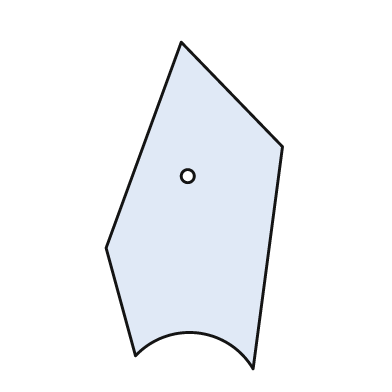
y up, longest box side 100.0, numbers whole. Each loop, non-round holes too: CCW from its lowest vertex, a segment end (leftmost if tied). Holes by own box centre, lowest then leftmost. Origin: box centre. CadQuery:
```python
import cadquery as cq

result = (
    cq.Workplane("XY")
    .moveTo(18.0, -50.0)
    .lineTo(27.0, 18.0)
    .lineTo(-4.0, 50.0)
    .lineTo(-27.0, -13.0)
    .lineTo(-18.0, -46.0)
    .threePointArc((1.0, -39.0), (18.0, -50.0))
    .close()
    .moveTo(-2.0, 9.0)
    .circle(2.0)
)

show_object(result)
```